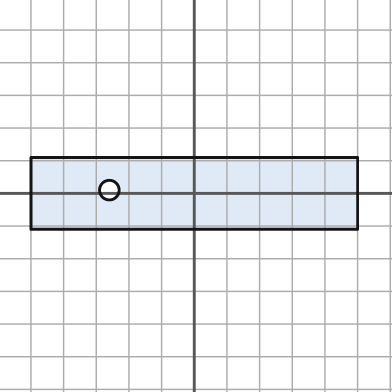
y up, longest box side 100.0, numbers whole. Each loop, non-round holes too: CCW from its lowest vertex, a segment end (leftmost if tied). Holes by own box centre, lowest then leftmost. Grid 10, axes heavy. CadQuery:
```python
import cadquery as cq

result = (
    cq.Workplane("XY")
    .moveTo(-50.0, -11.0)
    .lineTo(50.0, -11.0)
    .lineTo(50.0, 11.0)
    .lineTo(-50.0, 11.0)
    .close()
    .moveTo(-26.0, 1.0)
    .circle(3.0)
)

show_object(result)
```